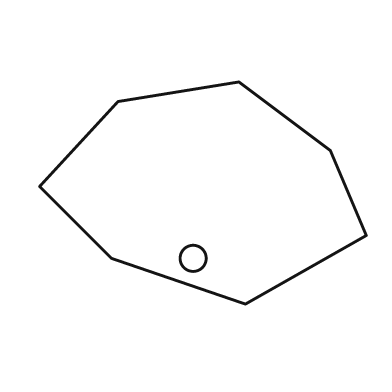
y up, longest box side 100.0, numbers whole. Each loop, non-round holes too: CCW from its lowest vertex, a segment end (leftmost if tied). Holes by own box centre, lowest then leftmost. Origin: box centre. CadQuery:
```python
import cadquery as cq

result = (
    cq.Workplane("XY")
    .moveTo(13.0, -34.0)
    .lineTo(50.0, -13.0)
    .lineTo(39.0, 13.0)
    .lineTo(11.0, 34.0)
    .lineTo(-26.0, 28.0)
    .lineTo(-50.0, 2.0)
    .lineTo(-28.0, -20.0)
    .close()
    .moveTo(-3.0, -20.0)
    .circle(4.0)
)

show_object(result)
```